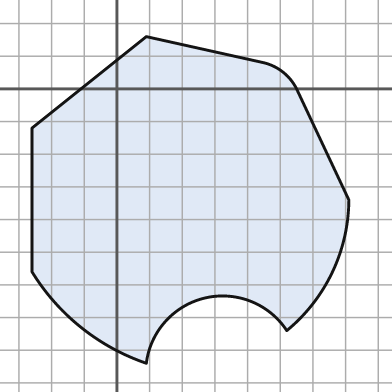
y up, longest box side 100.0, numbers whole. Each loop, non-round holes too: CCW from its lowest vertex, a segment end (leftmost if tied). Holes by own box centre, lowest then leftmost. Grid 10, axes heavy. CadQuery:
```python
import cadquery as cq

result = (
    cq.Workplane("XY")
    .moveTo(9.0, -84.0)
    .threePointArc((27.0, -64.0), (52.0, -74.0))
    .threePointArc((66.0, -56.0), (71.0, -34.0))
    .lineTo(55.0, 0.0)
    .threePointArc((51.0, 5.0), (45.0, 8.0))
    .lineTo(9.0, 16.0)
    .lineTo(-26.0, -12.0)
    .lineTo(-26.0, -56.0)
    .threePointArc((-11.0, -73.0), (9.0, -84.0))
    .close()
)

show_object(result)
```